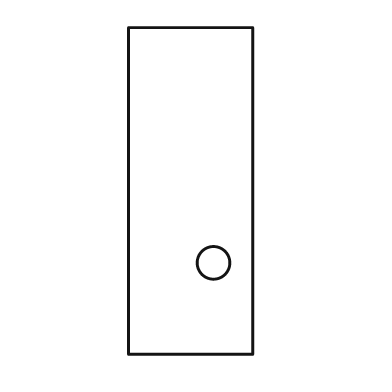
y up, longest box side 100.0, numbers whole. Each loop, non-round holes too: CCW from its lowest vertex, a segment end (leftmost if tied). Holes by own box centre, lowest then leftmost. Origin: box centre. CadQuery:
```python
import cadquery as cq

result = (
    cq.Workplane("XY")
    .moveTo(-19.0, -50.0)
    .lineTo(19.0, -50.0)
    .lineTo(19.0, 50.0)
    .lineTo(-19.0, 50.0)
    .close()
    .moveTo(7.0, -22.0)
    .circle(5.0)
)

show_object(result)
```